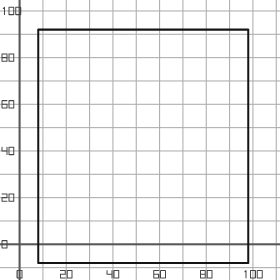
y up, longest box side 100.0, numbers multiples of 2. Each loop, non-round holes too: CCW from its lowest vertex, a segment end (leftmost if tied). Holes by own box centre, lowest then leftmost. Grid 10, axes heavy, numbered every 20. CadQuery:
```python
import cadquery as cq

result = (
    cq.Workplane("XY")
    .moveTo(8.0, -8.0)
    .lineTo(98.0, -8.0)
    .lineTo(98.0, 92.0)
    .lineTo(8.0, 92.0)
    .close()
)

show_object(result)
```